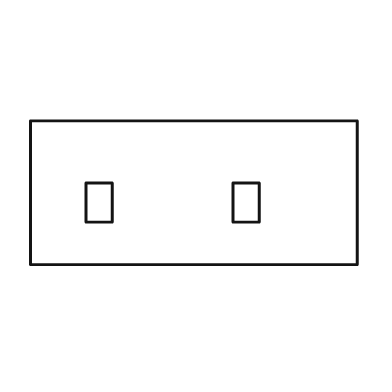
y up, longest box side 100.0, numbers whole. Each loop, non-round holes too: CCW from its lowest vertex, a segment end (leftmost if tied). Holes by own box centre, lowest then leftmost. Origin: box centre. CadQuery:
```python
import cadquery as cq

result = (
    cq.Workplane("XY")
    .moveTo(-50.0, -22.0)
    .lineTo(50.0, -22.0)
    .lineTo(50.0, 22.0)
    .lineTo(-50.0, 22.0)
    .close()
    .moveTo(-33.0, -9.0)
    .lineTo(-25.0, -9.0)
    .lineTo(-25.0, 3.0)
    .lineTo(-33.0, 3.0)
    .close()
    .moveTo(12.0, -9.0)
    .lineTo(20.0, -9.0)
    .lineTo(20.0, 3.0)
    .lineTo(12.0, 3.0)
    .close()
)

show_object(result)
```